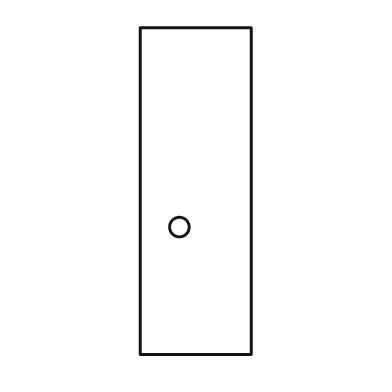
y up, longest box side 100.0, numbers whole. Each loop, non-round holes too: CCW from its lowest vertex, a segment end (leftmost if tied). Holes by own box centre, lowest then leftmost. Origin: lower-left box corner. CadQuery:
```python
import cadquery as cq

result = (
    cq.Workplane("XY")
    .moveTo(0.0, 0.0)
    .lineTo(34.0, 0.0)
    .lineTo(34.0, 100.0)
    .lineTo(0.0, 100.0)
    .close()
    .moveTo(12.0, 39.0)
    .circle(3.0)
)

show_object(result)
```